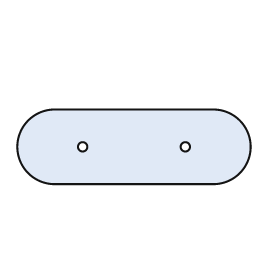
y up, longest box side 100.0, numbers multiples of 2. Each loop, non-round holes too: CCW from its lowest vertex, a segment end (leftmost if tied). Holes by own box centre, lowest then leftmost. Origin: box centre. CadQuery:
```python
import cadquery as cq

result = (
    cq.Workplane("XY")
    .moveTo(-34.0, -16.0)
    .lineTo(34.0, -16.0)
    .threePointArc((50.0, 0.0), (34.0, 16.0))
    .lineTo(-34.0, 16.0)
    .threePointArc((-50.0, 0.0), (-34.0, -16.0))
    .close()
    .moveTo(-22.0, 0.0)
    .circle(2.0)
    .moveTo(22.0, 0.0)
    .circle(2.0)
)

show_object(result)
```